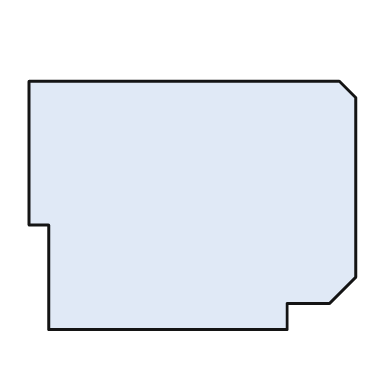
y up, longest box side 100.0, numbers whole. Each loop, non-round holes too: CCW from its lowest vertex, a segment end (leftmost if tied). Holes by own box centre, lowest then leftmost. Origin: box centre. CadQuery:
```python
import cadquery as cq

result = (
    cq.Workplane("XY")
    .moveTo(-44.0, -38.0)
    .lineTo(29.0, -38.0)
    .lineTo(29.0, -30.0)
    .lineTo(42.0, -30.0)
    .lineTo(50.0, -22.0)
    .lineTo(50.0, 33.0)
    .lineTo(45.0, 38.0)
    .lineTo(-50.0, 38.0)
    .lineTo(-50.0, -6.0)
    .lineTo(-44.0, -6.0)
    .close()
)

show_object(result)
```